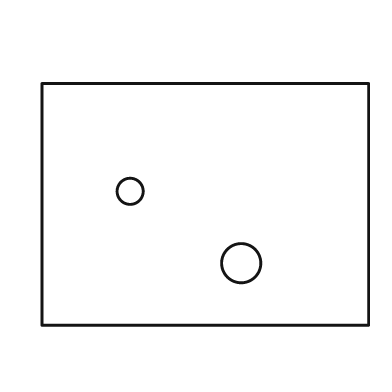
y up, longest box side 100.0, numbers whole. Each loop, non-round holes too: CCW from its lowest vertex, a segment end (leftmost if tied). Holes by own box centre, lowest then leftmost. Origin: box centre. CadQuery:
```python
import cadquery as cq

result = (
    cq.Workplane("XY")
    .moveTo(-50.0, -37.0)
    .lineTo(50.0, -37.0)
    .lineTo(50.0, 37.0)
    .lineTo(-50.0, 37.0)
    .close()
    .moveTo(11.0, -18.0)
    .circle(6.0)
    .moveTo(-23.0, 4.0)
    .circle(4.0)
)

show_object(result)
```